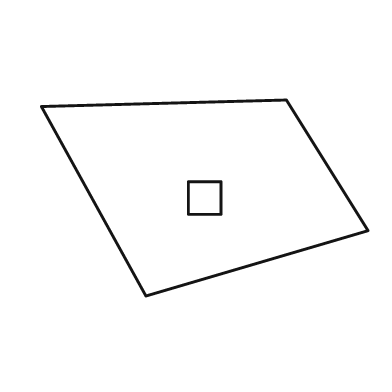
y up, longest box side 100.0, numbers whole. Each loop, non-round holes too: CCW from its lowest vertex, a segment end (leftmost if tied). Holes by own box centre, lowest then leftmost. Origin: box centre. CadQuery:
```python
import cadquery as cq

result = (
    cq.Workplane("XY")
    .moveTo(-18.0, -30.0)
    .lineTo(50.0, -10.0)
    .lineTo(25.0, 30.0)
    .lineTo(-50.0, 28.0)
    .close()
    .moveTo(-5.0, -5.0)
    .lineTo(5.0, -5.0)
    .lineTo(5.0, 5.0)
    .lineTo(-5.0, 5.0)
    .close()
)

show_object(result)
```